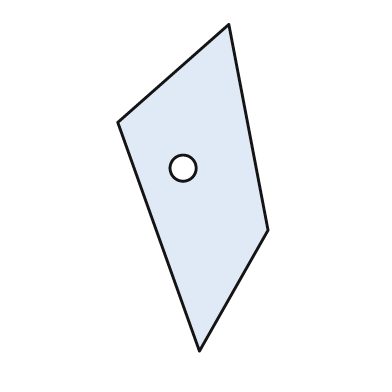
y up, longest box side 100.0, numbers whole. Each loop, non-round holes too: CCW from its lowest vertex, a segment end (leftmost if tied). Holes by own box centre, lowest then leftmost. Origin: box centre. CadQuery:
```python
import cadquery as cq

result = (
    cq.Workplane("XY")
    .moveTo(2.0, -50.0)
    .lineTo(23.0, -13.0)
    .lineTo(11.0, 50.0)
    .lineTo(-23.0, 20.0)
    .close()
    .moveTo(-3.0, 6.0)
    .circle(4.0)
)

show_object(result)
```